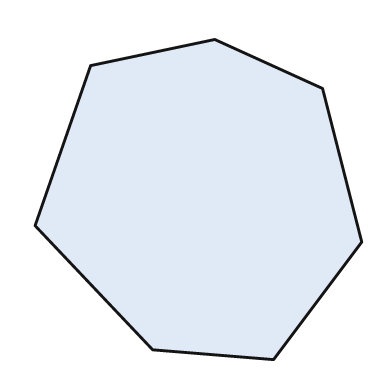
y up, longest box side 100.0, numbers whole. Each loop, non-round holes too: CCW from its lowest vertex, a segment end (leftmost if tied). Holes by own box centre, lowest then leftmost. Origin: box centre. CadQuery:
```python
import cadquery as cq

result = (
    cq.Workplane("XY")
    .moveTo(23.0, -49.0)
    .lineTo(50.0, -13.0)
    .lineTo(38.0, 34.0)
    .lineTo(5.0, 49.0)
    .lineTo(-33.0, 41.0)
    .lineTo(-50.0, -8.0)
    .lineTo(-14.0, -46.0)
    .close()
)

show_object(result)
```